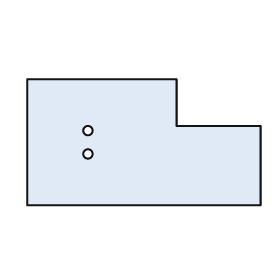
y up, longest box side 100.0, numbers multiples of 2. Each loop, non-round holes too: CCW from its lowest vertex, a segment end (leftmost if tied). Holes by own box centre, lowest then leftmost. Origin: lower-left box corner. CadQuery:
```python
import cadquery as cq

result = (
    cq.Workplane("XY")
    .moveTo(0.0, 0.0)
    .lineTo(100.0, 0.0)
    .lineTo(100.0, 34.0)
    .lineTo(64.0, 34.0)
    .lineTo(64.0, 54.0)
    .lineTo(0.0, 54.0)
    .close()
    .moveTo(26.0, 22.0)
    .circle(2.0)
    .moveTo(26.0, 32.0)
    .circle(2.0)
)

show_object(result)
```